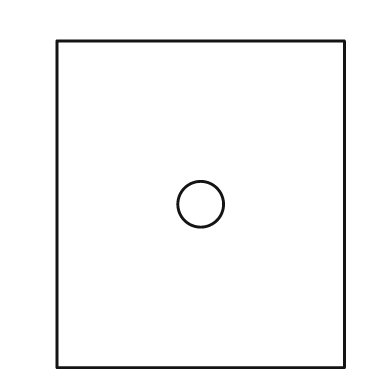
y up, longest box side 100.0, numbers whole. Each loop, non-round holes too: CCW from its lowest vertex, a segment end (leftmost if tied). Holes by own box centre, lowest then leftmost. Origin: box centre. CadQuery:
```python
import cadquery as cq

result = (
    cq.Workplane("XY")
    .moveTo(-44.0, -50.0)
    .lineTo(44.0, -50.0)
    .lineTo(44.0, 50.0)
    .lineTo(-44.0, 50.0)
    .close()
    .moveTo(0.0, 0.0)
    .circle(7.0)
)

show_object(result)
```